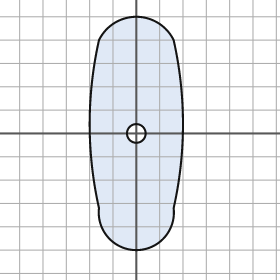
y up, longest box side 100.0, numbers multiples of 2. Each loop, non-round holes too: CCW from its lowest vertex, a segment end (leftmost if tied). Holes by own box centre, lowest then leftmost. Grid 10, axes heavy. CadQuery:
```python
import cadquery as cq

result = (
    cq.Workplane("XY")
    .moveTo(-16.0, -32.0)
    .threePointArc((0.0, -50.0), (16.0, -32.0))
    .threePointArc((20.0, 4.0), (16.0, 40.0))
    .threePointArc((0.0, 50.0), (-16.0, 40.0))
    .threePointArc((-20.0, 4.0), (-16.0, -32.0))
    .close()
    .moveTo(0.0, 0.0)
    .circle(4.0)
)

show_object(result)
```